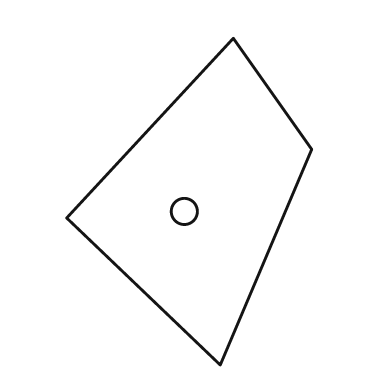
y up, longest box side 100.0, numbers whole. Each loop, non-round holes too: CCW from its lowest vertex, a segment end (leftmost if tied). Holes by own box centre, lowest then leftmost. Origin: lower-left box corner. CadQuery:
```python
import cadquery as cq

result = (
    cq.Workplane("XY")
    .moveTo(47.0, 0.0)
    .lineTo(75.0, 66.0)
    .lineTo(51.0, 100.0)
    .lineTo(0.0, 45.0)
    .close()
    .moveTo(36.0, 47.0)
    .circle(4.0)
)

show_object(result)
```